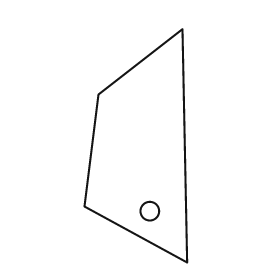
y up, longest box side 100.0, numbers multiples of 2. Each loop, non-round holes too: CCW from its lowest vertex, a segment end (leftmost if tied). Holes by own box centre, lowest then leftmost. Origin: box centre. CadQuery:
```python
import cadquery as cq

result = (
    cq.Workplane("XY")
    .moveTo(22.0, -50.0)
    .lineTo(20.0, 50.0)
    .lineTo(-16.0, 22.0)
    .lineTo(-22.0, -26.0)
    .close()
    .moveTo(6.0, -28.0)
    .circle(4.0)
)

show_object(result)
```